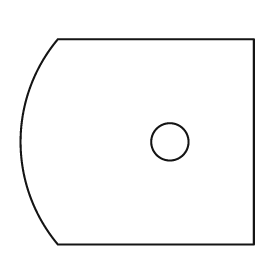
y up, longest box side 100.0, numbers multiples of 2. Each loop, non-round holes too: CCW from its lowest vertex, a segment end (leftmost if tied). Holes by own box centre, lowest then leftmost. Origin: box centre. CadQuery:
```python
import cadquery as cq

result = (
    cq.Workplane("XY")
    .moveTo(-34.0, -44.0)
    .lineTo(50.0, -44.0)
    .lineTo(50.0, 44.0)
    .lineTo(-34.0, 44.0)
    .threePointArc((-50.0, 0.0), (-34.0, -44.0))
    .close()
    .moveTo(14.0, 0.0)
    .circle(8.0)
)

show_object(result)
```